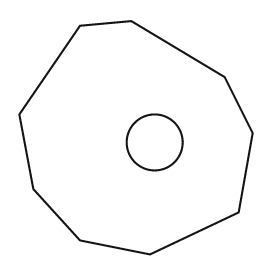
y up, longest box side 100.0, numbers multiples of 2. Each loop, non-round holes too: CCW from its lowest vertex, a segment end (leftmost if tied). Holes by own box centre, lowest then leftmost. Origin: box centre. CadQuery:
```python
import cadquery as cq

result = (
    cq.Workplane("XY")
    .moveTo(6.0, -50.0)
    .lineTo(44.0, -32.0)
    .lineTo(50.0, 2.0)
    .lineTo(38.0, 26.0)
    .lineTo(-2.0, 50.0)
    .lineTo(-24.0, 48.0)
    .lineTo(-50.0, 10.0)
    .lineTo(-44.0, -22.0)
    .lineTo(-24.0, -44.0)
    .close()
    .moveTo(8.0, -2.0)
    .circle(12.0)
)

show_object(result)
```